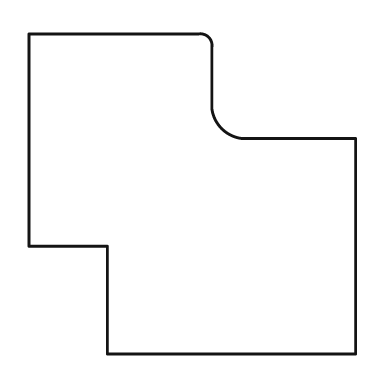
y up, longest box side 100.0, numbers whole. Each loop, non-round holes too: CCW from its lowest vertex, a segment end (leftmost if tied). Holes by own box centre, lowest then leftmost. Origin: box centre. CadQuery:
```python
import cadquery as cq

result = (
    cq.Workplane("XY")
    .moveTo(-26.0, -49.0)
    .lineTo(50.0, -49.0)
    .lineTo(50.0, 17.0)
    .lineTo(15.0, 17.0)
    .threePointArc((9.0, 20.0), (6.0, 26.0))
    .lineTo(6.0, 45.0)
    .threePointArc((5.0, 48.0), (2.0, 49.0))
    .lineTo(-50.0, 49.0)
    .lineTo(-50.0, -16.0)
    .lineTo(-26.0, -16.0)
    .close()
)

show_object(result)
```